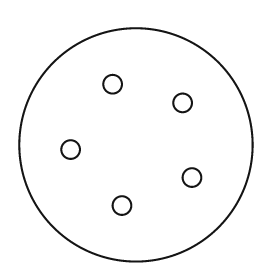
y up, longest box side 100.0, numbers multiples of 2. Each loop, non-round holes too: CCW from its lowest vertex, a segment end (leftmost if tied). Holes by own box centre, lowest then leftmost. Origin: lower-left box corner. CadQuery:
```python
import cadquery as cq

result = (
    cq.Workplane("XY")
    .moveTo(50.0, 50.0)
    .circle(50.0)
    .moveTo(44.0, 24.0)
    .circle(4.0)
    .moveTo(74.0, 36.0)
    .circle(4.0)
    .moveTo(22.0, 48.0)
    .circle(4.0)
    .moveTo(70.0, 68.0)
    .circle(4.0)
    .moveTo(40.0, 76.0)
    .circle(4.0)
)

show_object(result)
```